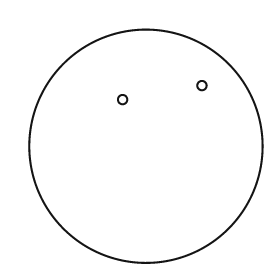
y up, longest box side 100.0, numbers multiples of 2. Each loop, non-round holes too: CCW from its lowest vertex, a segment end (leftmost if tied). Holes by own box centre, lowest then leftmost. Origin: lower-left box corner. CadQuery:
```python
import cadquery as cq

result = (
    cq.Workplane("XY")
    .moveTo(50.0, 50.0)
    .circle(50.0)
    .moveTo(40.0, 70.0)
    .circle(2.0)
    .moveTo(74.0, 76.0)
    .circle(2.0)
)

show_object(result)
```